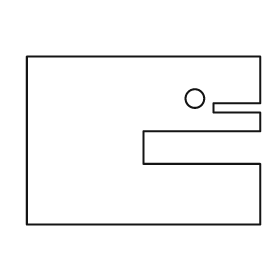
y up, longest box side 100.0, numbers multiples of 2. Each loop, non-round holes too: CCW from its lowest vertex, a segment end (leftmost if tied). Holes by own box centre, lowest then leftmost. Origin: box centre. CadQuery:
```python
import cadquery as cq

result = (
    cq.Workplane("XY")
    .moveTo(-50.0, -36.0)
    .lineTo(50.0, -36.0)
    .lineTo(50.0, -10.0)
    .lineTo(0.0, -10.0)
    .lineTo(0.0, 4.0)
    .lineTo(50.0, 4.0)
    .lineTo(50.0, 12.0)
    .lineTo(30.0, 12.0)
    .lineTo(30.0, 16.0)
    .lineTo(50.0, 16.0)
    .lineTo(50.0, 36.0)
    .lineTo(-50.0, 36.0)
    .close()
    .moveTo(22.0, 18.0)
    .circle(4.0)
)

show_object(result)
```